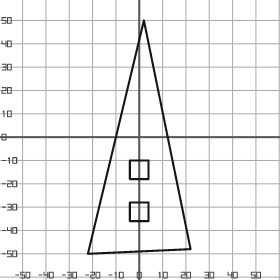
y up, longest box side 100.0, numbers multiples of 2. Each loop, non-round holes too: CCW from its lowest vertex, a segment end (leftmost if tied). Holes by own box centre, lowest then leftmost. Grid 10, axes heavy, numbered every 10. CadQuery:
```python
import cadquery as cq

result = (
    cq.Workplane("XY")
    .moveTo(-22.0, -50.0)
    .lineTo(22.0, -48.0)
    .lineTo(2.0, 50.0)
    .close()
    .moveTo(-4.0, -36.0)
    .lineTo(4.0, -36.0)
    .lineTo(4.0, -28.0)
    .lineTo(-4.0, -28.0)
    .close()
    .moveTo(-4.0, -18.0)
    .lineTo(4.0, -18.0)
    .lineTo(4.0, -10.0)
    .lineTo(-4.0, -10.0)
    .close()
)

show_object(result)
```